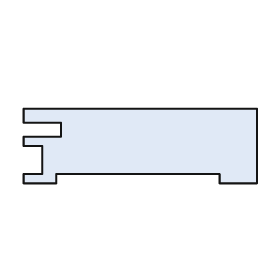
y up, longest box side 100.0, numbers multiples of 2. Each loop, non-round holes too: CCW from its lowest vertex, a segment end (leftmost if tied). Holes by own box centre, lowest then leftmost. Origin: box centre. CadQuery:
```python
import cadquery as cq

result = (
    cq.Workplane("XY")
    .moveTo(-50.0, -16.0)
    .lineTo(-36.0, -16.0)
    .lineTo(-36.0, -12.0)
    .lineTo(34.0, -12.0)
    .lineTo(34.0, -16.0)
    .lineTo(50.0, -16.0)
    .lineTo(50.0, 16.0)
    .lineTo(-50.0, 16.0)
    .lineTo(-50.0, 10.0)
    .lineTo(-34.0, 10.0)
    .lineTo(-34.0, 4.0)
    .lineTo(-50.0, 4.0)
    .lineTo(-50.0, 0.0)
    .lineTo(-42.0, 0.0)
    .lineTo(-42.0, -12.0)
    .lineTo(-50.0, -12.0)
    .close()
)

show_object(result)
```